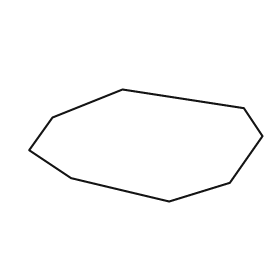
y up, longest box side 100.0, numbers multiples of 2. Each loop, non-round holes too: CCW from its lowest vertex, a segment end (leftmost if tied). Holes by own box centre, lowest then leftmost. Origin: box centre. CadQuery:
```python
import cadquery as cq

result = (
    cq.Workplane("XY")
    .moveTo(10.0, -24.0)
    .lineTo(36.0, -16.0)
    .lineTo(50.0, 4.0)
    .lineTo(42.0, 16.0)
    .lineTo(-10.0, 24.0)
    .lineTo(-40.0, 12.0)
    .lineTo(-50.0, -2.0)
    .lineTo(-32.0, -14.0)
    .close()
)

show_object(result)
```